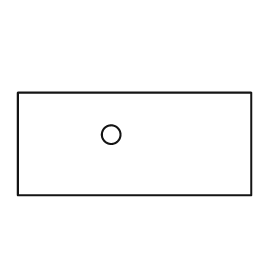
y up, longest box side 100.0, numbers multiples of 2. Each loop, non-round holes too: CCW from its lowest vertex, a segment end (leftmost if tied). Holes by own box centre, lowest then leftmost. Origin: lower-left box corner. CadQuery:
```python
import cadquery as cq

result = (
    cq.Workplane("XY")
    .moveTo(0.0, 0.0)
    .lineTo(100.0, 0.0)
    .lineTo(100.0, 44.0)
    .lineTo(0.0, 44.0)
    .close()
    .moveTo(40.0, 26.0)
    .circle(4.0)
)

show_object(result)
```